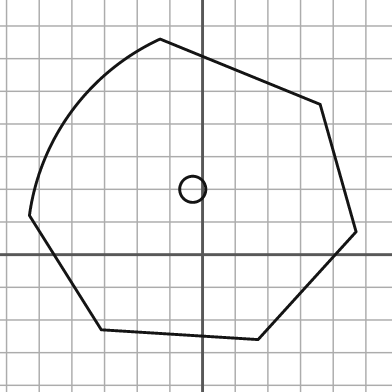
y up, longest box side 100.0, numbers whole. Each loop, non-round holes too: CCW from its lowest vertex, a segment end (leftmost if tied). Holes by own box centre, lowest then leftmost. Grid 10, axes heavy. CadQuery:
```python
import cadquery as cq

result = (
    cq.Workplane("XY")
    .moveTo(17.0, -26.0)
    .lineTo(47.0, 7.0)
    .lineTo(36.0, 46.0)
    .lineTo(-13.0, 66.0)
    .threePointArc((-40.0, 44.0), (-53.0, 12.0))
    .lineTo(-31.0, -23.0)
    .close()
    .moveTo(-3.0, 20.0)
    .circle(4.0)
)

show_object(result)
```